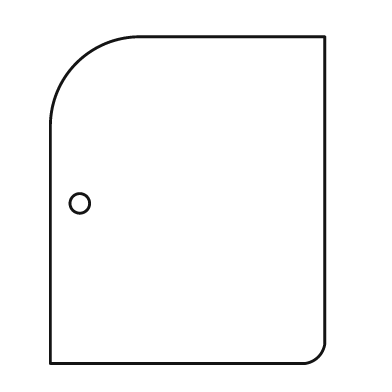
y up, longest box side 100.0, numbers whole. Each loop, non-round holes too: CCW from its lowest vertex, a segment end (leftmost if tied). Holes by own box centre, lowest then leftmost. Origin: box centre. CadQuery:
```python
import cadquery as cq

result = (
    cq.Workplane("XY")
    .moveTo(-42.0, -50.0)
    .lineTo(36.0, -50.0)
    .threePointArc((40.0, -48.0), (42.0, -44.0))
    .lineTo(42.0, 50.0)
    .lineTo(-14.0, 50.0)
    .threePointArc((-34.0, 42.0), (-42.0, 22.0))
    .close()
    .moveTo(-33.0, -1.0)
    .circle(3.0)
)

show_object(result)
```